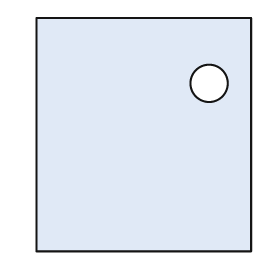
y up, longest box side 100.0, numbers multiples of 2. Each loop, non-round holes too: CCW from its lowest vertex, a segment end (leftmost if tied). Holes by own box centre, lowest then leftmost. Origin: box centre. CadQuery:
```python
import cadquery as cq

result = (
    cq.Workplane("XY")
    .moveTo(-46.0, -50.0)
    .lineTo(46.0, -50.0)
    .lineTo(46.0, 50.0)
    .lineTo(-46.0, 50.0)
    .close()
    .moveTo(28.0, 22.0)
    .circle(8.0)
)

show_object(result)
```